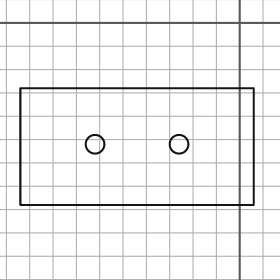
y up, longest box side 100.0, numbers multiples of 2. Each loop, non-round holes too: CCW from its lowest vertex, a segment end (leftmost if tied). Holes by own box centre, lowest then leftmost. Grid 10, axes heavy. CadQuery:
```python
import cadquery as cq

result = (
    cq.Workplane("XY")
    .moveTo(-94.0, -78.0)
    .lineTo(6.0, -78.0)
    .lineTo(6.0, -28.0)
    .lineTo(-94.0, -28.0)
    .close()
    .moveTo(-62.0, -52.0)
    .circle(4.0)
    .moveTo(-26.0, -52.0)
    .circle(4.0)
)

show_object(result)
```